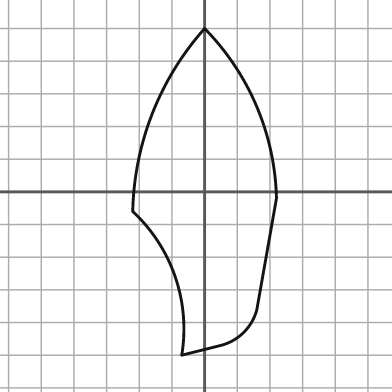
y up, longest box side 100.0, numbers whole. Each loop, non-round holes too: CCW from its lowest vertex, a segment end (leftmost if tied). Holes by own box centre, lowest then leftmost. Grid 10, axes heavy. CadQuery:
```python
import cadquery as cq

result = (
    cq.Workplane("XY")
    .moveTo(-7.0, -50.0)
    .lineTo(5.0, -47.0)
    .threePointArc((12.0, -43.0), (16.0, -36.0))
    .lineTo(22.0, -2.0)
    .threePointArc((16.0, 26.0), (0.0, 50.0))
    .threePointArc((-16.0, 24.0), (-22.0, -6.0))
    .threePointArc((-9.0, -26.0), (-7.0, -50.0))
    .close()
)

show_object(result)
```